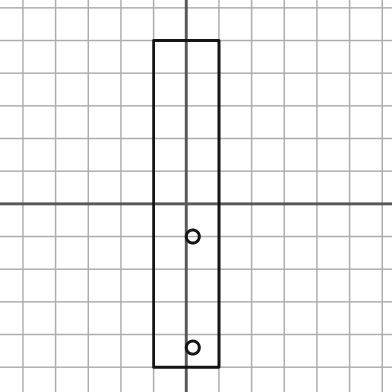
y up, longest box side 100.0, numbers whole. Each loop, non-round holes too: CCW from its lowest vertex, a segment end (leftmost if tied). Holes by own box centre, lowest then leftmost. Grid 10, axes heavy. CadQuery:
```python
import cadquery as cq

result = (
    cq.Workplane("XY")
    .moveTo(-10.0, -50.0)
    .lineTo(10.0, -50.0)
    .lineTo(10.0, 50.0)
    .lineTo(-10.0, 50.0)
    .close()
    .moveTo(2.0, -44.0)
    .circle(2.0)
    .moveTo(2.0, -10.0)
    .circle(2.0)
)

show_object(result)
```